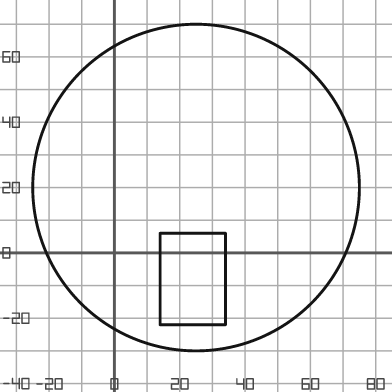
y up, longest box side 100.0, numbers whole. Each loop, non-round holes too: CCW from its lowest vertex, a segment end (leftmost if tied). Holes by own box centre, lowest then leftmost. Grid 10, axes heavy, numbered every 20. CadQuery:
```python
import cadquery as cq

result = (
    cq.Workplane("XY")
    .moveTo(25.0, 20.0)
    .circle(50.0)
    .moveTo(14.0, -22.0)
    .lineTo(34.0, -22.0)
    .lineTo(34.0, 6.0)
    .lineTo(14.0, 6.0)
    .close()
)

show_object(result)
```